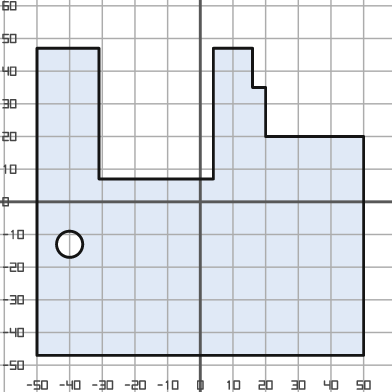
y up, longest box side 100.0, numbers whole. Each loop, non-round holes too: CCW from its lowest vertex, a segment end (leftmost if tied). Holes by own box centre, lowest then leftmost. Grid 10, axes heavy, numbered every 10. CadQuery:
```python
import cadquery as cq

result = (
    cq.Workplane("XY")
    .moveTo(-50.0, -47.0)
    .lineTo(50.0, -47.0)
    .lineTo(50.0, 20.0)
    .lineTo(20.0, 20.0)
    .lineTo(20.0, 35.0)
    .lineTo(16.0, 35.0)
    .lineTo(16.0, 47.0)
    .lineTo(4.0, 47.0)
    .lineTo(4.0, 7.0)
    .lineTo(-31.0, 7.0)
    .lineTo(-31.0, 47.0)
    .lineTo(-50.0, 47.0)
    .close()
    .moveTo(-40.0, -13.0)
    .circle(4.0)
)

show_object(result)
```